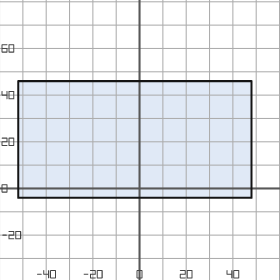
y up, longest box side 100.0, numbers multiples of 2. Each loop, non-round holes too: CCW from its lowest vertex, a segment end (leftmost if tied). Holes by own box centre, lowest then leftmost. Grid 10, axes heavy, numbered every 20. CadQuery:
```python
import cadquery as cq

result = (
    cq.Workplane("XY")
    .moveTo(-52.0, -4.0)
    .lineTo(48.0, -4.0)
    .lineTo(48.0, 46.0)
    .lineTo(-52.0, 46.0)
    .close()
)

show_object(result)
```